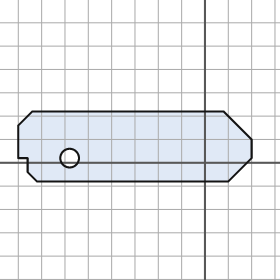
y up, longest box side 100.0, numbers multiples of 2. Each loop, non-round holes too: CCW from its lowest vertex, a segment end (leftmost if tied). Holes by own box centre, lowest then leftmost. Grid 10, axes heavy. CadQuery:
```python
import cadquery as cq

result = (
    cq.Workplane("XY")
    .moveTo(-72.0, -8.0)
    .lineTo(10.0, -8.0)
    .lineTo(20.0, 2.0)
    .lineTo(20.0, 10.0)
    .lineTo(8.0, 22.0)
    .lineTo(-74.0, 22.0)
    .lineTo(-80.0, 16.0)
    .lineTo(-80.0, 2.0)
    .lineTo(-76.0, 2.0)
    .lineTo(-76.0, -4.0)
    .close()
    .moveTo(-58.0, 2.0)
    .circle(4.0)
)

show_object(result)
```